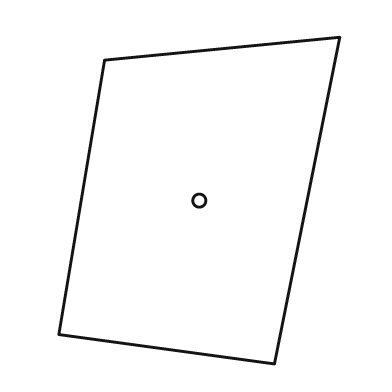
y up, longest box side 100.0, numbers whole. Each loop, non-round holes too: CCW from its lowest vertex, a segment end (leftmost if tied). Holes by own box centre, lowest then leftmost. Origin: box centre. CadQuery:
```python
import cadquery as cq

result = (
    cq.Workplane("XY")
    .moveTo(23.0, -50.0)
    .lineTo(43.0, 50.0)
    .lineTo(-29.0, 43.0)
    .lineTo(-43.0, -41.0)
    .close()
    .moveTo(0.0, 0.0)
    .circle(2.0)
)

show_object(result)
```